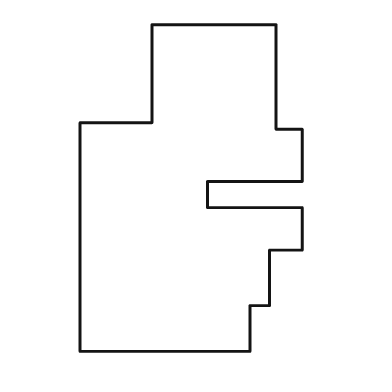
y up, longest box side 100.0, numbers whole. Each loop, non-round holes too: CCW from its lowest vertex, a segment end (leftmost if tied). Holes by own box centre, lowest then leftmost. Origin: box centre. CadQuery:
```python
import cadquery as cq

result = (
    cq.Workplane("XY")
    .moveTo(-34.0, -50.0)
    .lineTo(18.0, -50.0)
    .lineTo(18.0, -36.0)
    .lineTo(24.0, -36.0)
    .lineTo(24.0, -19.0)
    .lineTo(34.0, -19.0)
    .lineTo(34.0, -6.0)
    .lineTo(5.0, -6.0)
    .lineTo(5.0, 2.0)
    .lineTo(34.0, 2.0)
    .lineTo(34.0, 18.0)
    .lineTo(26.0, 18.0)
    .lineTo(26.0, 50.0)
    .lineTo(-12.0, 50.0)
    .lineTo(-12.0, 20.0)
    .lineTo(-34.0, 20.0)
    .close()
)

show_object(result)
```